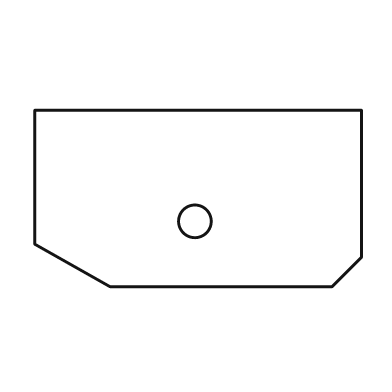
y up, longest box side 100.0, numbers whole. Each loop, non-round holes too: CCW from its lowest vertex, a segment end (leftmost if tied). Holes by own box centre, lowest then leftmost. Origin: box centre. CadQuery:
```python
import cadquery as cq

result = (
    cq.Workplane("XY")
    .moveTo(-27.0, -27.0)
    .lineTo(41.0, -27.0)
    .lineTo(50.0, -18.0)
    .lineTo(50.0, 27.0)
    .lineTo(-50.0, 27.0)
    .lineTo(-50.0, -14.0)
    .close()
    .moveTo(-1.0, -7.0)
    .circle(5.0)
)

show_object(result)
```